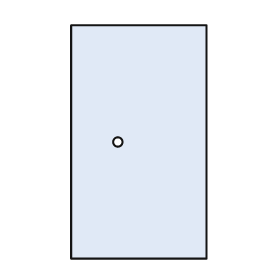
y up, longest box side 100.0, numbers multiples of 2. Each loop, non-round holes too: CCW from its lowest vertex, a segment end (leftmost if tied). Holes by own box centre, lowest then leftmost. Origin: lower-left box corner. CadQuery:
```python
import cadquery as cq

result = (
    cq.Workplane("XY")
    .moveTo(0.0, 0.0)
    .lineTo(58.0, 0.0)
    .lineTo(58.0, 100.0)
    .lineTo(0.0, 100.0)
    .close()
    .moveTo(20.0, 50.0)
    .circle(2.0)
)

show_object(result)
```